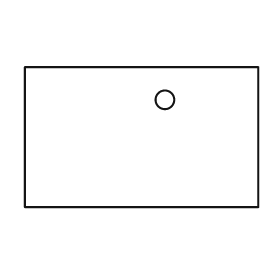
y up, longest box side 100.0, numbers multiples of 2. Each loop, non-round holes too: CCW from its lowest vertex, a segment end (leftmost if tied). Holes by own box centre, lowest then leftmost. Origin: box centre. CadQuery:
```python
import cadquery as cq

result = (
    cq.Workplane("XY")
    .moveTo(-50.0, -30.0)
    .lineTo(50.0, -30.0)
    .lineTo(50.0, 30.0)
    .lineTo(-50.0, 30.0)
    .close()
    .moveTo(10.0, 16.0)
    .circle(4.0)
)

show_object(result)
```